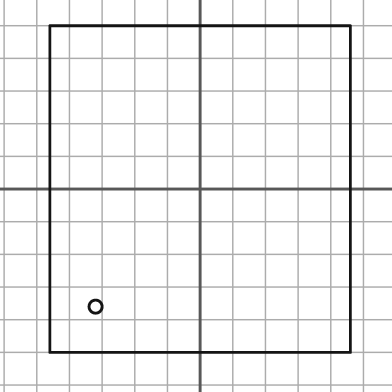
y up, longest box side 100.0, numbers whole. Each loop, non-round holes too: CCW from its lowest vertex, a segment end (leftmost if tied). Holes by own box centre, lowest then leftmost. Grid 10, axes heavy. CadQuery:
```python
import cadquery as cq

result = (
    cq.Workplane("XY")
    .moveTo(-46.0, -50.0)
    .lineTo(46.0, -50.0)
    .lineTo(46.0, 50.0)
    .lineTo(-46.0, 50.0)
    .close()
    .moveTo(-32.0, -36.0)
    .circle(2.0)
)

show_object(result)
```